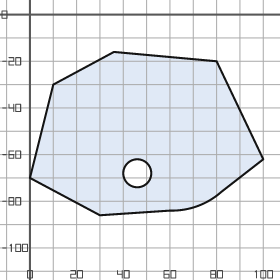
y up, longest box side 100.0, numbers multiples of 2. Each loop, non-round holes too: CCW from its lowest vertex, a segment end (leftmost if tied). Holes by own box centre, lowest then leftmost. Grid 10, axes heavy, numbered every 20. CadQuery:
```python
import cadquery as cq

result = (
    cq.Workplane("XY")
    .moveTo(30.0, -86.0)
    .lineTo(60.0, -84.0)
    .threePointArc((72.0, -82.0), (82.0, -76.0))
    .lineTo(100.0, -62.0)
    .lineTo(80.0, -20.0)
    .lineTo(36.0, -16.0)
    .lineTo(10.0, -30.0)
    .lineTo(0.0, -70.0)
    .close()
    .moveTo(46.0, -68.0)
    .circle(6.0)
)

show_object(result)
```